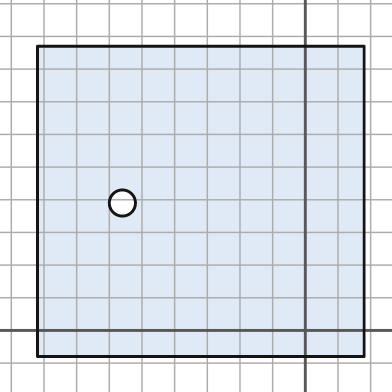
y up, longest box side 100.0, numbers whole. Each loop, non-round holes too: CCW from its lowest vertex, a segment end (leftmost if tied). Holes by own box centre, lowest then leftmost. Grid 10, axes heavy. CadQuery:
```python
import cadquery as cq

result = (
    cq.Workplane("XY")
    .moveTo(-82.0, -8.0)
    .lineTo(18.0, -8.0)
    .lineTo(18.0, 87.0)
    .lineTo(-82.0, 87.0)
    .close()
    .moveTo(-56.0, 39.0)
    .circle(4.0)
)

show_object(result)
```